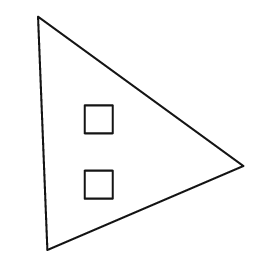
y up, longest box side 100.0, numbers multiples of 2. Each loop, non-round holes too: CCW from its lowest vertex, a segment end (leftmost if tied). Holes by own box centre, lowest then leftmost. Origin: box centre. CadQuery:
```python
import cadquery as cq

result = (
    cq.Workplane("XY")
    .moveTo(-40.0, -50.0)
    .lineTo(44.0, -14.0)
    .lineTo(-44.0, 50.0)
    .close()
    .moveTo(-24.0, -28.0)
    .lineTo(-12.0, -28.0)
    .lineTo(-12.0, -16.0)
    .lineTo(-24.0, -16.0)
    .close()
    .moveTo(-24.0, 0.0)
    .lineTo(-12.0, 0.0)
    .lineTo(-12.0, 12.0)
    .lineTo(-24.0, 12.0)
    .close()
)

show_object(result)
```